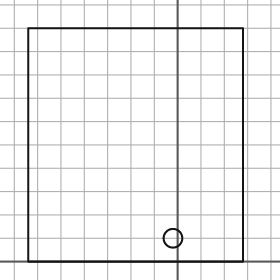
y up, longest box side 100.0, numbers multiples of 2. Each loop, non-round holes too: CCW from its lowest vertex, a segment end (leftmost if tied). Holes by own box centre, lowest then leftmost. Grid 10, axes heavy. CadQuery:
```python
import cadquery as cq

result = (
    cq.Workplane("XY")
    .moveTo(-64.0, 0.0)
    .lineTo(28.0, 0.0)
    .lineTo(28.0, 100.0)
    .lineTo(-64.0, 100.0)
    .close()
    .moveTo(-2.0, 10.0)
    .circle(4.0)
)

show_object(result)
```